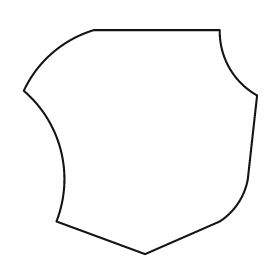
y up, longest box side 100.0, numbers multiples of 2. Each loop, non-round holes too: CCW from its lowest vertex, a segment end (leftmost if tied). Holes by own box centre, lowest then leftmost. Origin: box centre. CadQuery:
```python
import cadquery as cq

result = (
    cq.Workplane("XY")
    .moveTo(2.0, -48.0)
    .lineTo(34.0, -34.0)
    .threePointArc((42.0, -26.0), (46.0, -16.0))
    .lineTo(50.0, 20.0)
    .threePointArc((38.0, 32.0), (34.0, 48.0))
    .lineTo(-20.0, 48.0)
    .threePointArc((-38.0, 38.0), (-50.0, 22.0))
    .threePointArc((-34.0, -4.0), (-36.0, -34.0))
    .close()
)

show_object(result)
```